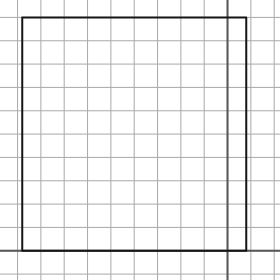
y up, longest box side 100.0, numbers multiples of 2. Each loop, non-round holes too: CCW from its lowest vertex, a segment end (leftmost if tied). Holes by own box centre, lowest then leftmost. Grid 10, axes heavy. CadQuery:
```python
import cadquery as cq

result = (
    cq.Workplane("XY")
    .moveTo(-88.0, 0.0)
    .lineTo(8.0, 0.0)
    .lineTo(8.0, 100.0)
    .lineTo(-88.0, 100.0)
    .close()
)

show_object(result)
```